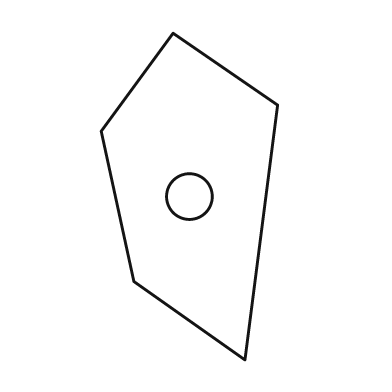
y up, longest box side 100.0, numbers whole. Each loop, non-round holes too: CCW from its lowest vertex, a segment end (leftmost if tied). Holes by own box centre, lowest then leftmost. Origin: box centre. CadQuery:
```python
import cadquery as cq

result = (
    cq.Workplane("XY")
    .moveTo(17.0, -50.0)
    .lineTo(27.0, 28.0)
    .lineTo(-5.0, 50.0)
    .lineTo(-27.0, 20.0)
    .lineTo(-17.0, -26.0)
    .close()
    .moveTo(0.0, 0.0)
    .circle(7.0)
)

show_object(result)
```